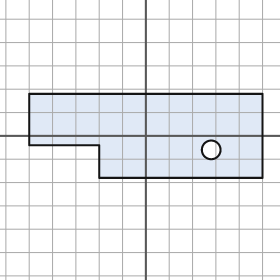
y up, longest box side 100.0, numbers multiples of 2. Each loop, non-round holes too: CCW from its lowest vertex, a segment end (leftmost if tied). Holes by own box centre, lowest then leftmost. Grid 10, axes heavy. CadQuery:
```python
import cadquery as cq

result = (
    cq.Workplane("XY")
    .moveTo(-20.0, -18.0)
    .lineTo(50.0, -18.0)
    .lineTo(50.0, 18.0)
    .lineTo(-50.0, 18.0)
    .lineTo(-50.0, -4.0)
    .lineTo(-20.0, -4.0)
    .close()
    .moveTo(28.0, -6.0)
    .circle(4.0)
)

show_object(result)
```